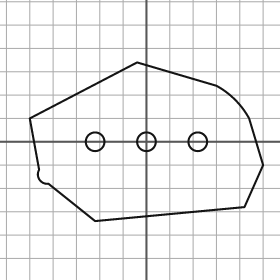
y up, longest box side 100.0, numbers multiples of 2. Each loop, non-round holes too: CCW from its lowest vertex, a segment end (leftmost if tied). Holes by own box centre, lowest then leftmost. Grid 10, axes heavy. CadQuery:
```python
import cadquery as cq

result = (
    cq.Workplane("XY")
    .moveTo(-22.0, -34.0)
    .lineTo(42.0, -28.0)
    .lineTo(50.0, -10.0)
    .lineTo(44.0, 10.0)
    .threePointArc((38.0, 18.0), (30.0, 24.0))
    .lineTo(-4.0, 34.0)
    .lineTo(-50.0, 10.0)
    .lineTo(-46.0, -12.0)
    .threePointArc((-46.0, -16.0), (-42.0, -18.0))
    .close()
    .moveTo(-22.0, 0.0)
    .circle(4.0)
    .moveTo(0.0, 0.0)
    .circle(4.0)
    .moveTo(22.0, 0.0)
    .circle(4.0)
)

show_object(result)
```